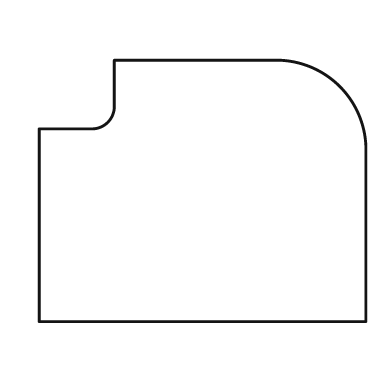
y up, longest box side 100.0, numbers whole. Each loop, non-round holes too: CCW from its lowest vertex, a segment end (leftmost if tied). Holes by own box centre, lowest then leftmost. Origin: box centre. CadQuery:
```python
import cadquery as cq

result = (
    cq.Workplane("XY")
    .moveTo(-50.0, -40.0)
    .lineTo(50.0, -40.0)
    .lineTo(50.0, 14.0)
    .threePointArc((42.0, 32.0), (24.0, 40.0))
    .lineTo(-27.0, 40.0)
    .lineTo(-27.0, 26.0)
    .threePointArc((-29.0, 21.0), (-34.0, 19.0))
    .lineTo(-50.0, 19.0)
    .close()
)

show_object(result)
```